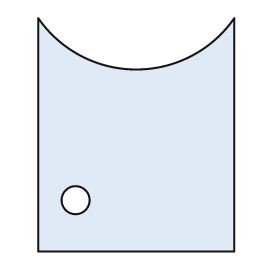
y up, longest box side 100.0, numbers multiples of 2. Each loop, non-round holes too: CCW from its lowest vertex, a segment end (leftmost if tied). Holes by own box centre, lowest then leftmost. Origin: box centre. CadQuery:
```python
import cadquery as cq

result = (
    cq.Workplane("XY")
    .moveTo(-42.0, -50.0)
    .lineTo(42.0, -50.0)
    .lineTo(42.0, 50.0)
    .threePointArc((0.0, 28.0), (-42.0, 50.0))
    .close()
    .moveTo(-26.0, -28.0)
    .circle(6.0)
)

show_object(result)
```